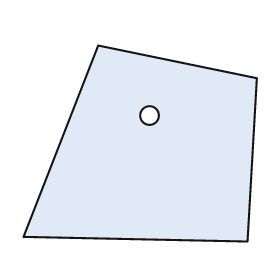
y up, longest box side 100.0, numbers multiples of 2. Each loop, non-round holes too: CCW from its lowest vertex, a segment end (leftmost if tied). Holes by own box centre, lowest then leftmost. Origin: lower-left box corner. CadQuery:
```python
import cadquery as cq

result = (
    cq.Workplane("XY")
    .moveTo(96.0, 0.0)
    .lineTo(100.0, 70.0)
    .lineTo(32.0, 84.0)
    .lineTo(0.0, 2.0)
    .close()
    .moveTo(54.0, 54.0)
    .circle(4.0)
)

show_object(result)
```